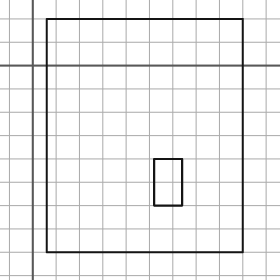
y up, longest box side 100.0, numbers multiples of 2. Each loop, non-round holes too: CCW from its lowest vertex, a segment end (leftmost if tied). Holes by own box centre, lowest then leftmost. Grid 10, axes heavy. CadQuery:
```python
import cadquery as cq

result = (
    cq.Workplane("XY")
    .moveTo(6.0, -80.0)
    .lineTo(90.0, -80.0)
    .lineTo(90.0, 20.0)
    .lineTo(6.0, 20.0)
    .close()
    .moveTo(52.0, -60.0)
    .lineTo(64.0, -60.0)
    .lineTo(64.0, -40.0)
    .lineTo(52.0, -40.0)
    .close()
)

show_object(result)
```